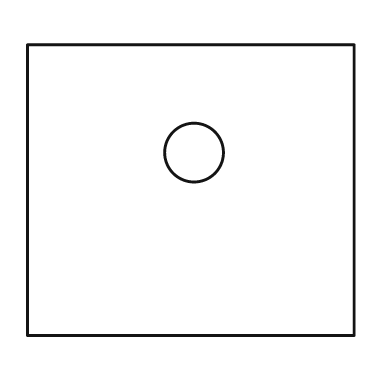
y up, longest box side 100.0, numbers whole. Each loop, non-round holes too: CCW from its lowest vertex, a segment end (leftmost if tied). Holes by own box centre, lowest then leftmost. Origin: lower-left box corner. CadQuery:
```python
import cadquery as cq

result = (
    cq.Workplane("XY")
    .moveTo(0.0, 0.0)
    .lineTo(100.0, 0.0)
    .lineTo(100.0, 89.0)
    .lineTo(0.0, 89.0)
    .close()
    .moveTo(51.0, 56.0)
    .circle(9.0)
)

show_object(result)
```